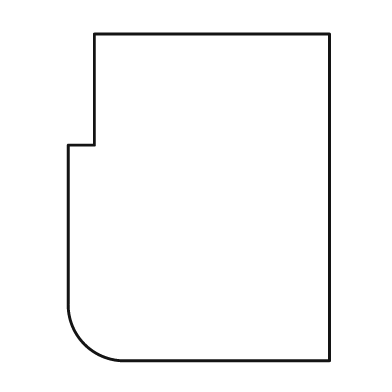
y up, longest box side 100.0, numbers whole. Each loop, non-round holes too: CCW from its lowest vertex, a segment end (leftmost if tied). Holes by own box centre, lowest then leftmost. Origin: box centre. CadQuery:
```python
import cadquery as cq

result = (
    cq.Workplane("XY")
    .moveTo(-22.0, -50.0)
    .lineTo(40.0, -50.0)
    .lineTo(40.0, 50.0)
    .lineTo(-32.0, 50.0)
    .lineTo(-32.0, 16.0)
    .lineTo(-40.0, 16.0)
    .lineTo(-40.0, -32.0)
    .threePointArc((-35.0, -45.0), (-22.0, -50.0))
    .close()
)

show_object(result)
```